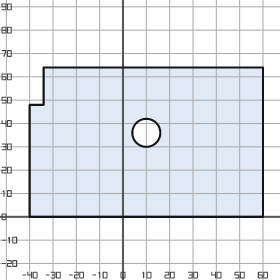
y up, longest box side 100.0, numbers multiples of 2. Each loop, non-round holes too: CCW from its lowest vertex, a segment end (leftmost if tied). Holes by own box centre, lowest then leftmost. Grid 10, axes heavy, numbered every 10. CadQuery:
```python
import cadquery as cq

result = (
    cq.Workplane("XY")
    .moveTo(-40.0, 0.0)
    .lineTo(60.0, 0.0)
    .lineTo(60.0, 64.0)
    .lineTo(-34.0, 64.0)
    .lineTo(-34.0, 48.0)
    .lineTo(-40.0, 48.0)
    .close()
    .moveTo(10.0, 36.0)
    .circle(6.0)
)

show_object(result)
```